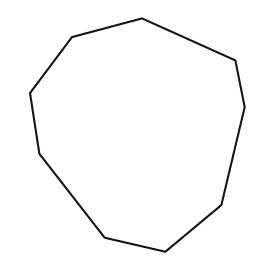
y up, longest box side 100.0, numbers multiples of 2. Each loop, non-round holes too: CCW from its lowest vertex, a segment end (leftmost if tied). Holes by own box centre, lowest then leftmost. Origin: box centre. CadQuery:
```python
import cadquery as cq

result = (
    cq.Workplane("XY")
    .moveTo(12.0, -50.0)
    .lineTo(36.0, -30.0)
    .lineTo(46.0, 12.0)
    .lineTo(42.0, 32.0)
    .lineTo(2.0, 50.0)
    .lineTo(-28.0, 42.0)
    .lineTo(-46.0, 18.0)
    .lineTo(-42.0, -8.0)
    .lineTo(-14.0, -44.0)
    .close()
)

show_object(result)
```